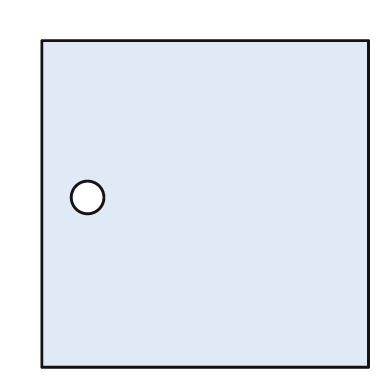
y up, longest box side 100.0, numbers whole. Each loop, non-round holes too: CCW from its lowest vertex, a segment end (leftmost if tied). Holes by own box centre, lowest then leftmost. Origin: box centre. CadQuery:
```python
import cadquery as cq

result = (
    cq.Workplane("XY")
    .moveTo(-50.0, -50.0)
    .lineTo(50.0, -50.0)
    .lineTo(50.0, 50.0)
    .lineTo(-50.0, 50.0)
    .close()
    .moveTo(-36.0, 2.0)
    .circle(5.0)
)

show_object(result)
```